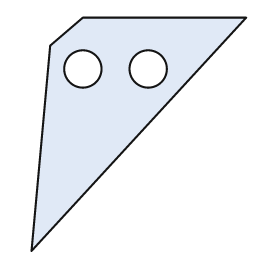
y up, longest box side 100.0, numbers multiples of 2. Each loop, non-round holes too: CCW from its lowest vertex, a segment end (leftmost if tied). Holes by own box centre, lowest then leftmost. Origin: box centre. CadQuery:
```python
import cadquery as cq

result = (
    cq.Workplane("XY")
    .moveTo(-46.0, -50.0)
    .lineTo(46.0, 50.0)
    .lineTo(-24.0, 50.0)
    .lineTo(-38.0, 38.0)
    .close()
    .moveTo(-24.0, 28.0)
    .circle(8.0)
    .moveTo(4.0, 28.0)
    .circle(8.0)
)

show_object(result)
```